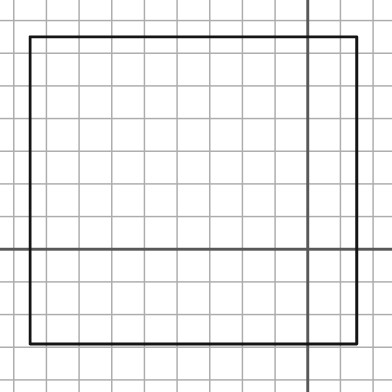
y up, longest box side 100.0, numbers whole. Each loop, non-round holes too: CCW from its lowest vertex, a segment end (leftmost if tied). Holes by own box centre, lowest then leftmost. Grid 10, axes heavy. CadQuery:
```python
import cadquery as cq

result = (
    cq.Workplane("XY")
    .moveTo(-85.0, -29.0)
    .lineTo(15.0, -29.0)
    .lineTo(15.0, 65.0)
    .lineTo(-85.0, 65.0)
    .close()
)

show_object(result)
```